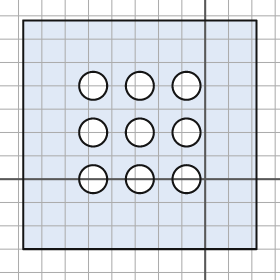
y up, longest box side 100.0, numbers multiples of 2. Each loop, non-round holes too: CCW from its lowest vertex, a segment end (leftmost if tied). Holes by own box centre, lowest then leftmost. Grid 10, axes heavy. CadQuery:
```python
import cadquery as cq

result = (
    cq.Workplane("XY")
    .moveTo(-78.0, -30.0)
    .lineTo(22.0, -30.0)
    .lineTo(22.0, 68.0)
    .lineTo(-78.0, 68.0)
    .close()
    .moveTo(-48.0, 0.0)
    .circle(6.0)
    .moveTo(-28.0, 0.0)
    .circle(6.0)
    .moveTo(-8.0, 0.0)
    .circle(6.0)
    .moveTo(-48.0, 20.0)
    .circle(6.0)
    .moveTo(-28.0, 20.0)
    .circle(6.0)
    .moveTo(-8.0, 20.0)
    .circle(6.0)
    .moveTo(-48.0, 40.0)
    .circle(6.0)
    .moveTo(-28.0, 40.0)
    .circle(6.0)
    .moveTo(-8.0, 40.0)
    .circle(6.0)
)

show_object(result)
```